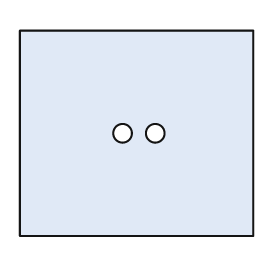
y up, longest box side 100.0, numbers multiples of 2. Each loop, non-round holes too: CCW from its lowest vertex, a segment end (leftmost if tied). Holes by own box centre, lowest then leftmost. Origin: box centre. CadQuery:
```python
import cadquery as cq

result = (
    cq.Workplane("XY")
    .moveTo(-50.0, -44.0)
    .lineTo(50.0, -44.0)
    .lineTo(50.0, 44.0)
    .lineTo(-50.0, 44.0)
    .close()
    .moveTo(-6.0, 0.0)
    .circle(4.0)
    .moveTo(8.0, 0.0)
    .circle(4.0)
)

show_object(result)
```